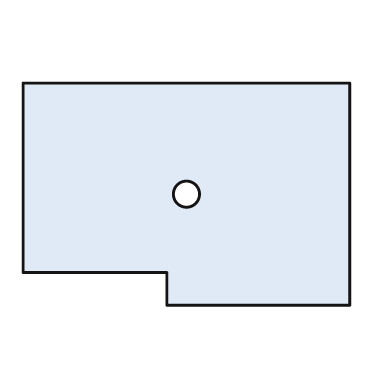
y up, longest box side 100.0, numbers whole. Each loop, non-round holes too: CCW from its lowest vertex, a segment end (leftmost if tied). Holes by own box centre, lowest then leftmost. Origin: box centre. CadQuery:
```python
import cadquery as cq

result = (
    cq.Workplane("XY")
    .moveTo(-6.0, -34.0)
    .lineTo(50.0, -34.0)
    .lineTo(50.0, 34.0)
    .lineTo(-50.0, 34.0)
    .lineTo(-50.0, -24.0)
    .lineTo(-6.0, -24.0)
    .close()
    .moveTo(0.0, 0.0)
    .circle(4.0)
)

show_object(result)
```